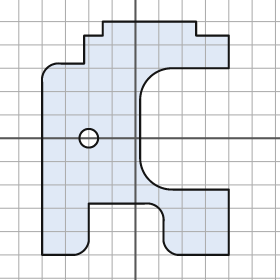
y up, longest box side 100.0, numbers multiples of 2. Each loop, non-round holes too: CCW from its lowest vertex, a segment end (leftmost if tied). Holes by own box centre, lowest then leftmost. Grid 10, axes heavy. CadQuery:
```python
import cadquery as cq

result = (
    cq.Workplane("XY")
    .moveTo(-40.0, -50.0)
    .lineTo(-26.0, -50.0)
    .threePointArc((-22.0, -48.0), (-20.0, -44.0))
    .lineTo(-20.0, -28.0)
    .lineTo(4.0, -28.0)
    .threePointArc((10.0, -30.0), (12.0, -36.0))
    .lineTo(12.0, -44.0)
    .threePointArc((14.0, -48.0), (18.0, -50.0))
    .lineTo(40.0, -50.0)
    .lineTo(40.0, -22.0)
    .lineTo(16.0, -22.0)
    .threePointArc((6.0, -18.0), (2.0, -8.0))
    .lineTo(2.0, 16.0)
    .threePointArc((6.0, 26.0), (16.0, 30.0))
    .lineTo(40.0, 30.0)
    .lineTo(40.0, 44.0)
    .lineTo(26.0, 44.0)
    .lineTo(26.0, 50.0)
    .lineTo(-14.0, 50.0)
    .lineTo(-14.0, 44.0)
    .lineTo(-22.0, 44.0)
    .lineTo(-22.0, 32.0)
    .lineTo(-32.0, 32.0)
    .threePointArc((-38.0, 30.0), (-40.0, 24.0))
    .close()
    .moveTo(-20.0, 0.0)
    .circle(4.0)
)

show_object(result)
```